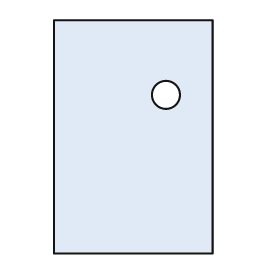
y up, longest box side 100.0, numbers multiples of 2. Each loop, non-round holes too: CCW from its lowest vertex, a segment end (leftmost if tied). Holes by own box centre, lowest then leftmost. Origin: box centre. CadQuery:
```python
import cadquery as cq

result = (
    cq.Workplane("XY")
    .moveTo(-34.0, -50.0)
    .lineTo(34.0, -50.0)
    .lineTo(34.0, 50.0)
    .lineTo(-34.0, 50.0)
    .close()
    .moveTo(14.0, 18.0)
    .circle(6.0)
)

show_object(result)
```